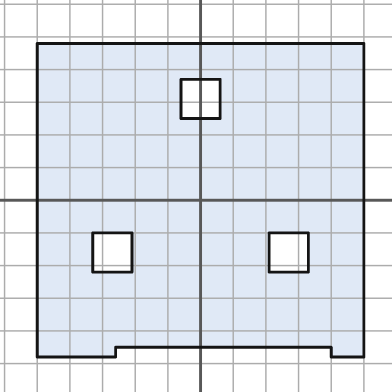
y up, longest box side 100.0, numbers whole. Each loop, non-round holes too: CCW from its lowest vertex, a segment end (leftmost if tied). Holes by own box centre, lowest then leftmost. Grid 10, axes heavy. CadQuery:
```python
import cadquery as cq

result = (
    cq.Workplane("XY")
    .moveTo(-50.0, -48.0)
    .lineTo(-26.0, -48.0)
    .lineTo(-26.0, -45.0)
    .lineTo(40.0, -45.0)
    .lineTo(40.0, -48.0)
    .lineTo(50.0, -48.0)
    .lineTo(50.0, 48.0)
    .lineTo(-50.0, 48.0)
    .close()
    .moveTo(-33.0, -22.0)
    .lineTo(-21.0, -22.0)
    .lineTo(-21.0, -10.0)
    .lineTo(-33.0, -10.0)
    .close()
    .moveTo(21.0, -22.0)
    .lineTo(33.0, -22.0)
    .lineTo(33.0, -10.0)
    .lineTo(21.0, -10.0)
    .close()
    .moveTo(-6.0, 25.0)
    .lineTo(6.0, 25.0)
    .lineTo(6.0, 37.0)
    .lineTo(-6.0, 37.0)
    .close()
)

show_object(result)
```